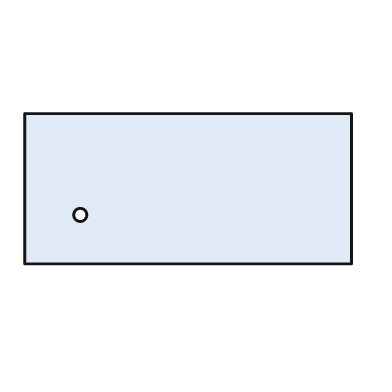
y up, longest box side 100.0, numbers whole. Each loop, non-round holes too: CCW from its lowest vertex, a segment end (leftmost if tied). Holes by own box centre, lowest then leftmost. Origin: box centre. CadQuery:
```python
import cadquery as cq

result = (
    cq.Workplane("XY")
    .moveTo(-50.0, -23.0)
    .lineTo(50.0, -23.0)
    .lineTo(50.0, 23.0)
    .lineTo(-50.0, 23.0)
    .close()
    .moveTo(-33.0, -8.0)
    .circle(2.0)
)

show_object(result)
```